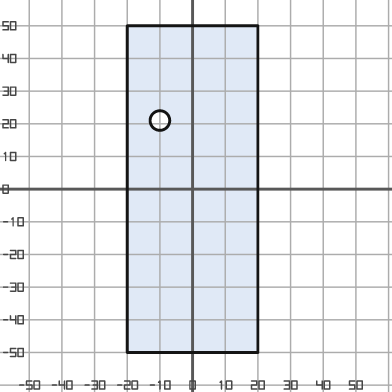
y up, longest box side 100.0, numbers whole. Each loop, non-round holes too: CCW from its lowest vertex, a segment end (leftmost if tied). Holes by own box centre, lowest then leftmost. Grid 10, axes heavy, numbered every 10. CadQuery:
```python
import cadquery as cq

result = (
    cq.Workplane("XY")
    .moveTo(-20.0, -50.0)
    .lineTo(20.0, -50.0)
    .lineTo(20.0, 50.0)
    .lineTo(-20.0, 50.0)
    .close()
    .moveTo(-10.0, 21.0)
    .circle(3.0)
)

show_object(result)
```